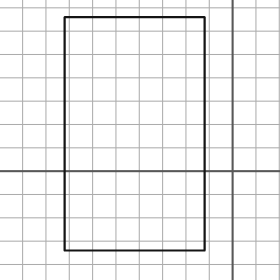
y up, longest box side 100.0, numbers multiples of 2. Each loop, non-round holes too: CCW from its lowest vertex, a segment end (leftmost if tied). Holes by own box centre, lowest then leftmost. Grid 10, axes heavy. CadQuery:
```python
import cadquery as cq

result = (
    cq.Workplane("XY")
    .moveTo(-72.0, -34.0)
    .lineTo(-12.0, -34.0)
    .lineTo(-12.0, 66.0)
    .lineTo(-72.0, 66.0)
    .close()
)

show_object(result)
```